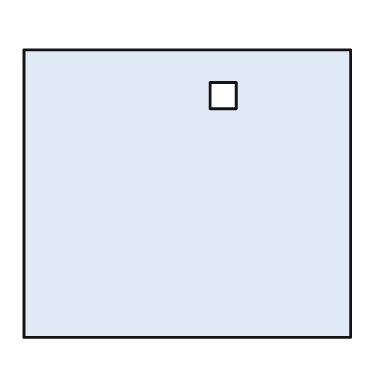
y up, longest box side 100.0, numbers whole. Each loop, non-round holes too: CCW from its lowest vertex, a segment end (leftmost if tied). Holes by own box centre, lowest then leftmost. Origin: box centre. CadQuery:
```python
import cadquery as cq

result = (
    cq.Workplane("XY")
    .moveTo(-50.0, -44.0)
    .lineTo(50.0, -44.0)
    .lineTo(50.0, 44.0)
    .lineTo(-50.0, 44.0)
    .close()
    .moveTo(7.0, 26.0)
    .lineTo(15.0, 26.0)
    .lineTo(15.0, 34.0)
    .lineTo(7.0, 34.0)
    .close()
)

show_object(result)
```